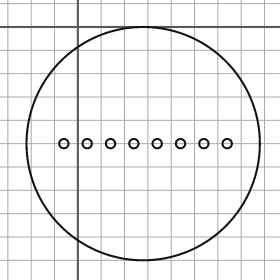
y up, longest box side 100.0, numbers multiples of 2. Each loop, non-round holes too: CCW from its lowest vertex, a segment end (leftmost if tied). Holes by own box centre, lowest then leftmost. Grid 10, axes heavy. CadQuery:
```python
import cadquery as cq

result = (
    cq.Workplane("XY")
    .moveTo(28.0, -50.0)
    .circle(50.0)
    .moveTo(-6.0, -50.0)
    .circle(2.0)
    .moveTo(4.0, -50.0)
    .circle(2.0)
    .moveTo(14.0, -50.0)
    .circle(2.0)
    .moveTo(24.0, -50.0)
    .circle(2.0)
    .moveTo(34.0, -50.0)
    .circle(2.0)
    .moveTo(44.0, -50.0)
    .circle(2.0)
    .moveTo(54.0, -50.0)
    .circle(2.0)
    .moveTo(64.0, -50.0)
    .circle(2.0)
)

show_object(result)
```